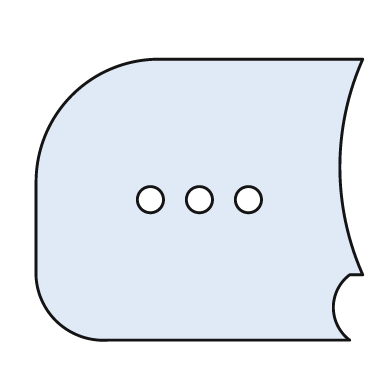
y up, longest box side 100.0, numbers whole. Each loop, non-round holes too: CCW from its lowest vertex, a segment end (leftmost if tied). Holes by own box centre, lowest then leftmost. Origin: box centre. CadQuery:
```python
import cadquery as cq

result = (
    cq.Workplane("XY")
    .moveTo(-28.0, -43.0)
    .lineTo(46.0, -43.0)
    .threePointArc((41.0, -33.0), (46.0, -23.0))
    .lineTo(50.0, -23.0)
    .threePointArc((43.0, 10.0), (50.0, 43.0))
    .lineTo(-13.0, 43.0)
    .threePointArc((-39.0, 32.0), (-50.0, 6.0))
    .lineTo(-50.0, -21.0)
    .threePointArc((-44.0, -37.0), (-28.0, -43.0))
    .close()
    .moveTo(-15.0, 0.0)
    .circle(4.0)
    .moveTo(0.0, 0.0)
    .circle(4.0)
    .moveTo(15.0, 0.0)
    .circle(4.0)
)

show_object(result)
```